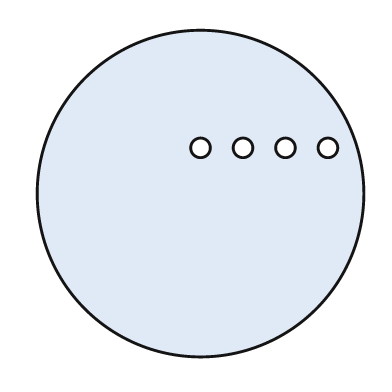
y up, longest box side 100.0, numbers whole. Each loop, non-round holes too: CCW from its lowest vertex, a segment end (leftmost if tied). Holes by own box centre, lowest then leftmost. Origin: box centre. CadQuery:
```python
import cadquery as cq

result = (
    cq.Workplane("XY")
    .moveTo(0.0, 0.0)
    .circle(50.0)
    .moveTo(0.0, 14.0)
    .circle(3.0)
    .moveTo(13.0, 14.0)
    .circle(3.0)
    .moveTo(26.0, 14.0)
    .circle(3.0)
    .moveTo(39.0, 14.0)
    .circle(3.0)
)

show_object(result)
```